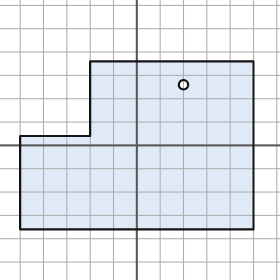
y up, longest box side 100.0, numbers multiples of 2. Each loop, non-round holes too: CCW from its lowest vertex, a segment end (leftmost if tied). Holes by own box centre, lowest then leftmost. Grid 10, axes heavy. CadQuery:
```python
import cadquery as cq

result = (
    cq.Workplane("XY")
    .moveTo(-50.0, -36.0)
    .lineTo(50.0, -36.0)
    .lineTo(50.0, 36.0)
    .lineTo(-20.0, 36.0)
    .lineTo(-20.0, 4.0)
    .lineTo(-50.0, 4.0)
    .close()
    .moveTo(20.0, 26.0)
    .circle(2.0)
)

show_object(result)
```